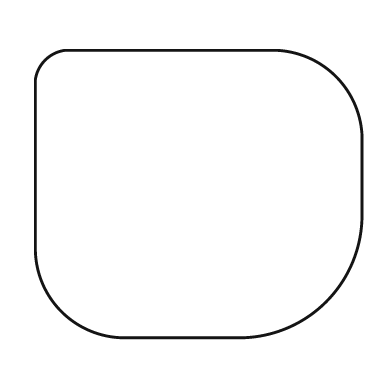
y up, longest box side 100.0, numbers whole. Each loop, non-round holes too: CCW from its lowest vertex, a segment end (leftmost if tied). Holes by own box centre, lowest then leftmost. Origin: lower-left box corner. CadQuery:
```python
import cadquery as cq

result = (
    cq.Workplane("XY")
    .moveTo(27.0, 0.0)
    .lineTo(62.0, 0.0)
    .threePointArc((89.0, 11.0), (100.0, 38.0))
    .lineTo(100.0, 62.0)
    .threePointArc((92.0, 80.0), (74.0, 88.0))
    .lineTo(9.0, 88.0)
    .threePointArc((3.0, 85.0), (0.0, 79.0))
    .lineTo(0.0, 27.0)
    .threePointArc((8.0, 8.0), (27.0, 0.0))
    .close()
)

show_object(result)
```